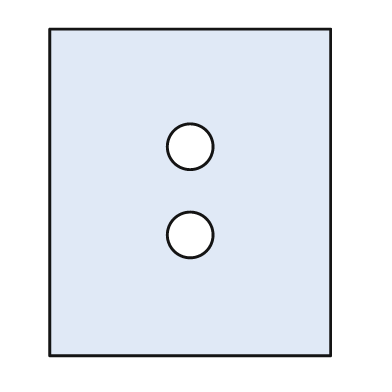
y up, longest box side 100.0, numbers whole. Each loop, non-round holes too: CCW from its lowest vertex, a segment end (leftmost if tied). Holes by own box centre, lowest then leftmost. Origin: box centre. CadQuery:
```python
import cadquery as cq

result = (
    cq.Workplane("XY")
    .moveTo(-43.0, -50.0)
    .lineTo(43.0, -50.0)
    .lineTo(43.0, 50.0)
    .lineTo(-43.0, 50.0)
    .close()
    .moveTo(0.0, -13.0)
    .circle(7.0)
    .moveTo(0.0, 14.0)
    .circle(7.0)
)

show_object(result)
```